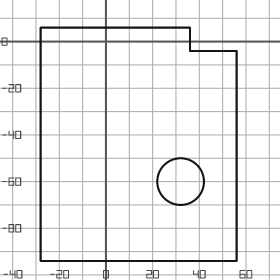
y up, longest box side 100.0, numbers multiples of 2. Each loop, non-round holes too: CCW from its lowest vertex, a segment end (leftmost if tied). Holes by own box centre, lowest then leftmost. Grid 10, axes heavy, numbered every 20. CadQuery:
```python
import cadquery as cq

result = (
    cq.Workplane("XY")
    .moveTo(-28.0, -94.0)
    .lineTo(56.0, -94.0)
    .lineTo(56.0, -4.0)
    .lineTo(36.0, -4.0)
    .lineTo(36.0, 6.0)
    .lineTo(-28.0, 6.0)
    .close()
    .moveTo(32.0, -60.0)
    .circle(10.0)
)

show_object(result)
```